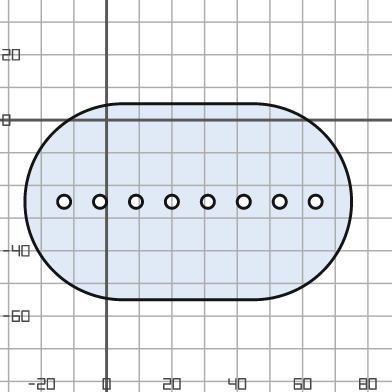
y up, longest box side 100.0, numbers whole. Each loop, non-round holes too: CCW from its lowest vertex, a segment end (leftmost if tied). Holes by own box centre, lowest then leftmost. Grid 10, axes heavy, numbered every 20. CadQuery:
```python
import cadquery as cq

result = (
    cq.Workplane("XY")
    .moveTo(5.0, -55.0)
    .lineTo(45.0, -55.0)
    .threePointArc((75.0, -25.0), (45.0, 5.0))
    .lineTo(5.0, 5.0)
    .threePointArc((-25.0, -25.0), (5.0, -55.0))
    .close()
    .moveTo(-13.0, -25.0)
    .circle(2.0)
    .moveTo(-2.0, -25.0)
    .circle(2.0)
    .moveTo(9.0, -25.0)
    .circle(2.0)
    .moveTo(20.0, -25.0)
    .circle(2.0)
    .moveTo(31.0, -25.0)
    .circle(2.0)
    .moveTo(42.0, -25.0)
    .circle(2.0)
    .moveTo(53.0, -25.0)
    .circle(2.0)
    .moveTo(64.0, -25.0)
    .circle(2.0)
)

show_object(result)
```